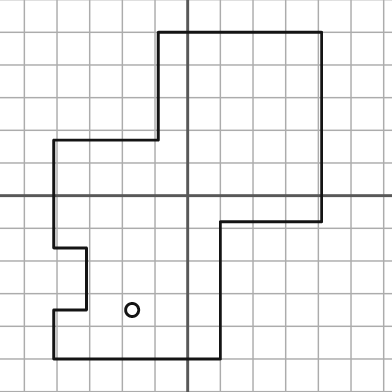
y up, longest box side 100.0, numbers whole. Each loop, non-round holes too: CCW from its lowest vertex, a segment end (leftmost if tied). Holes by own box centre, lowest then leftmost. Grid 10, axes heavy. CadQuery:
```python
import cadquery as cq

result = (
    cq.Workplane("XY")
    .moveTo(-41.0, -50.0)
    .lineTo(10.0, -50.0)
    .lineTo(10.0, -8.0)
    .lineTo(41.0, -8.0)
    .lineTo(41.0, 50.0)
    .lineTo(-9.0, 50.0)
    .lineTo(-9.0, 17.0)
    .lineTo(-41.0, 17.0)
    .lineTo(-41.0, -16.0)
    .lineTo(-31.0, -16.0)
    .lineTo(-31.0, -35.0)
    .lineTo(-41.0, -35.0)
    .close()
    .moveTo(-17.0, -35.0)
    .circle(2.0)
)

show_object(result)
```